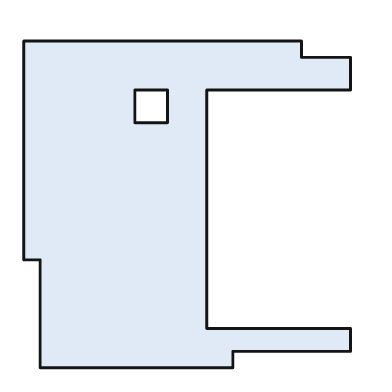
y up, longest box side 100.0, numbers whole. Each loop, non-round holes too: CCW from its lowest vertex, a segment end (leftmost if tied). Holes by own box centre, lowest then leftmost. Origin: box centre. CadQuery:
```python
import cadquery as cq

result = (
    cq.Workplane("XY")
    .moveTo(-45.0, -50.0)
    .lineTo(14.0, -50.0)
    .lineTo(14.0, -45.0)
    .lineTo(50.0, -45.0)
    .lineTo(50.0, -38.0)
    .lineTo(6.0, -38.0)
    .lineTo(6.0, 35.0)
    .lineTo(50.0, 35.0)
    .lineTo(50.0, 45.0)
    .lineTo(35.0, 45.0)
    .lineTo(35.0, 50.0)
    .lineTo(-50.0, 50.0)
    .lineTo(-50.0, -17.0)
    .lineTo(-45.0, -17.0)
    .close()
    .moveTo(-16.0, 25.0)
    .lineTo(-6.0, 25.0)
    .lineTo(-6.0, 35.0)
    .lineTo(-16.0, 35.0)
    .close()
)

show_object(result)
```